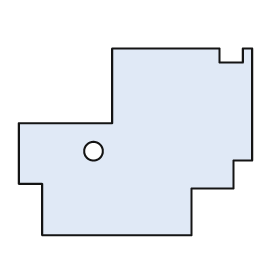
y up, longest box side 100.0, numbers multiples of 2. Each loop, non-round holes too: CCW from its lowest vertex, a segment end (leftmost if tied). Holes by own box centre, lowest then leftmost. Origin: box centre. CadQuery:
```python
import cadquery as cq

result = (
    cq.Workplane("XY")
    .moveTo(-40.0, -40.0)
    .lineTo(24.0, -40.0)
    .lineTo(24.0, -20.0)
    .lineTo(42.0, -20.0)
    .lineTo(42.0, -8.0)
    .lineTo(50.0, -8.0)
    .lineTo(50.0, 40.0)
    .lineTo(46.0, 40.0)
    .lineTo(46.0, 34.0)
    .lineTo(36.0, 34.0)
    .lineTo(36.0, 40.0)
    .lineTo(-10.0, 40.0)
    .lineTo(-10.0, 8.0)
    .lineTo(-50.0, 8.0)
    .lineTo(-50.0, -18.0)
    .lineTo(-40.0, -18.0)
    .close()
    .moveTo(-18.0, -4.0)
    .circle(4.0)
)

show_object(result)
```